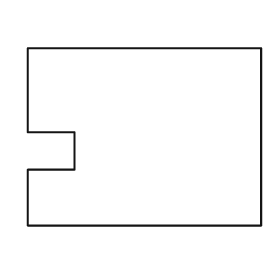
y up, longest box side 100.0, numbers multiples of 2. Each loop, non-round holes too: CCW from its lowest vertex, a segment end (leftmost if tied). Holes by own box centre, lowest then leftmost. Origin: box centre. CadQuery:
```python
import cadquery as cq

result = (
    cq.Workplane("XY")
    .moveTo(-50.0, -38.0)
    .lineTo(50.0, -38.0)
    .lineTo(50.0, 38.0)
    .lineTo(-50.0, 38.0)
    .lineTo(-50.0, 2.0)
    .lineTo(-30.0, 2.0)
    .lineTo(-30.0, -14.0)
    .lineTo(-50.0, -14.0)
    .close()
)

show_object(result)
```